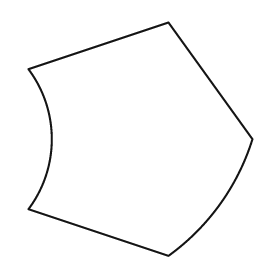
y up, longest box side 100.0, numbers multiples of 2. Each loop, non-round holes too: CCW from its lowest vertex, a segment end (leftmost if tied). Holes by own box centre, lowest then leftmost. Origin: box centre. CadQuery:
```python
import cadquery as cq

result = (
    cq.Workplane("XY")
    .moveTo(12.0, -50.0)
    .threePointArc((34.0, -28.0), (48.0, 0.0))
    .lineTo(12.0, 50.0)
    .lineTo(-48.0, 30.0)
    .threePointArc((-38.0, 0.0), (-48.0, -30.0))
    .close()
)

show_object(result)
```